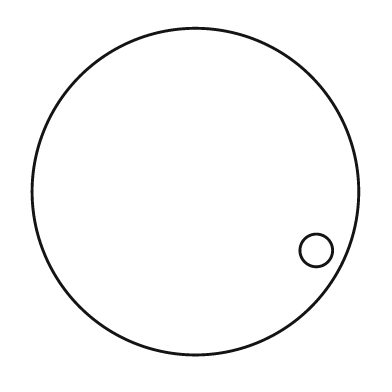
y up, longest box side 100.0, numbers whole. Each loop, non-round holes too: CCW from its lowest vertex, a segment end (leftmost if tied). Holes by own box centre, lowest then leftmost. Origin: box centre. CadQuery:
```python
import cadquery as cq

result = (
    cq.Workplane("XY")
    .moveTo(0.0, 0.0)
    .circle(50.0)
    .moveTo(37.0, -18.0)
    .circle(5.0)
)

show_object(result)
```